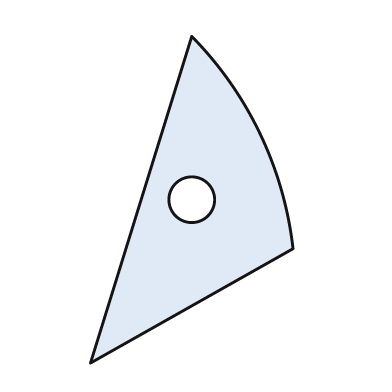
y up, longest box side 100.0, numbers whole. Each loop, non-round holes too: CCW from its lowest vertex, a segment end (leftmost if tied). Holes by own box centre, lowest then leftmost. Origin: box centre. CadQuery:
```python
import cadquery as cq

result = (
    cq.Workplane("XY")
    .moveTo(-31.0, -50.0)
    .lineTo(31.0, -15.0)
    .threePointArc((21.0, 20.0), (0.0, 50.0))
    .close()
    .moveTo(0.0, 0.0)
    .circle(7.0)
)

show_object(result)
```